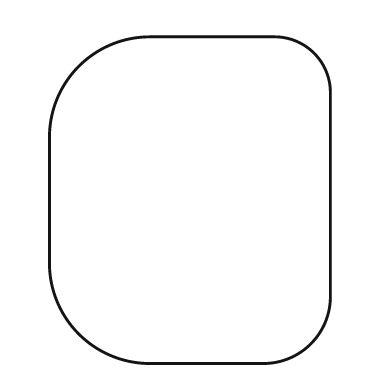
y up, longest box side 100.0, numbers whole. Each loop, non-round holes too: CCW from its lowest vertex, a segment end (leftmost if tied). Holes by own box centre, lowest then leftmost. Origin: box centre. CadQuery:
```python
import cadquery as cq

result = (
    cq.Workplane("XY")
    .moveTo(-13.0, -50.0)
    .lineTo(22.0, -50.0)
    .threePointArc((37.0, -44.0), (43.0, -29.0))
    .lineTo(43.0, 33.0)
    .threePointArc((38.0, 45.0), (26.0, 50.0))
    .lineTo(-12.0, 50.0)
    .threePointArc((-34.0, 41.0), (-43.0, 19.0))
    .lineTo(-43.0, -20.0)
    .threePointArc((-34.0, -41.0), (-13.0, -50.0))
    .close()
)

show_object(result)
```